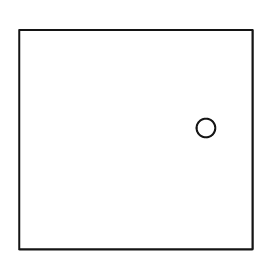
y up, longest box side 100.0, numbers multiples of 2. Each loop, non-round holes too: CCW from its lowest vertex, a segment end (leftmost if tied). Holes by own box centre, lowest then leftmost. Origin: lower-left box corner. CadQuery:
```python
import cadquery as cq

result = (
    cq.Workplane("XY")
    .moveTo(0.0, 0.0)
    .lineTo(100.0, 0.0)
    .lineTo(100.0, 94.0)
    .lineTo(0.0, 94.0)
    .close()
    .moveTo(80.0, 52.0)
    .circle(4.0)
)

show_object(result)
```